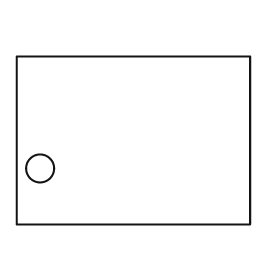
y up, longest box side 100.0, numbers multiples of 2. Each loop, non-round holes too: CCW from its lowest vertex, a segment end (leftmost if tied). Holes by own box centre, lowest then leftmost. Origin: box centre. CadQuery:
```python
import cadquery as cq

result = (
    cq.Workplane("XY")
    .moveTo(-50.0, -36.0)
    .lineTo(50.0, -36.0)
    .lineTo(50.0, 36.0)
    .lineTo(-50.0, 36.0)
    .close()
    .moveTo(-40.0, -12.0)
    .circle(6.0)
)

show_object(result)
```